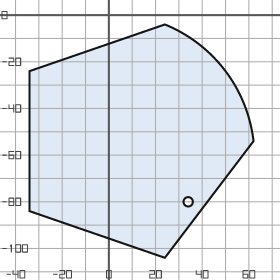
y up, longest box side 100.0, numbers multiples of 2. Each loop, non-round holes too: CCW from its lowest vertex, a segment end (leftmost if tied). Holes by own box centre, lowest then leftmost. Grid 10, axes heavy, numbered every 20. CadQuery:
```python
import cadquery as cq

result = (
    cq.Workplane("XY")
    .moveTo(24.0, -104.0)
    .lineTo(62.0, -54.0)
    .threePointArc((50.0, -24.0), (24.0, -4.0))
    .lineTo(-34.0, -24.0)
    .lineTo(-34.0, -84.0)
    .close()
    .moveTo(34.0, -80.0)
    .circle(2.0)
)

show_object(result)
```